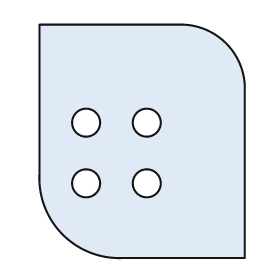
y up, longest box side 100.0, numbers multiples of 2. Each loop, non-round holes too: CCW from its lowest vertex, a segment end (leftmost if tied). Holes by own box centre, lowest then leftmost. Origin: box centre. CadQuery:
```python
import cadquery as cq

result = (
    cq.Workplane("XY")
    .moveTo(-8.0, -50.0)
    .lineTo(44.0, -50.0)
    .lineTo(44.0, 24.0)
    .threePointArc((36.0, 42.0), (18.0, 50.0))
    .lineTo(-44.0, 50.0)
    .lineTo(-44.0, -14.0)
    .threePointArc((-34.0, -40.0), (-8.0, -50.0))
    .close()
    .moveTo(-24.0, -18.0)
    .circle(6.0)
    .moveTo(2.0, -18.0)
    .circle(6.0)
    .moveTo(-24.0, 8.0)
    .circle(6.0)
    .moveTo(2.0, 8.0)
    .circle(6.0)
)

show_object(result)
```